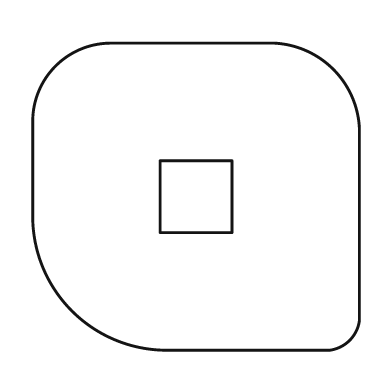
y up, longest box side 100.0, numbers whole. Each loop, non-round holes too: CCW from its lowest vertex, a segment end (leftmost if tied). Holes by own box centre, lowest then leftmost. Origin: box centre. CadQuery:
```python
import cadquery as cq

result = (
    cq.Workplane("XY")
    .moveTo(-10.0, -47.0)
    .lineTo(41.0, -47.0)
    .threePointArc((47.0, -44.0), (50.0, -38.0))
    .lineTo(50.0, 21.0)
    .threePointArc((42.0, 39.0), (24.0, 47.0))
    .lineTo(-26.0, 47.0)
    .threePointArc((-43.0, 40.0), (-50.0, 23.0))
    .lineTo(-50.0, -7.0)
    .threePointArc((-38.0, -35.0), (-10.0, -47.0))
    .close()
    .moveTo(-11.0, -11.0)
    .lineTo(11.0, -11.0)
    .lineTo(11.0, 11.0)
    .lineTo(-11.0, 11.0)
    .close()
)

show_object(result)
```